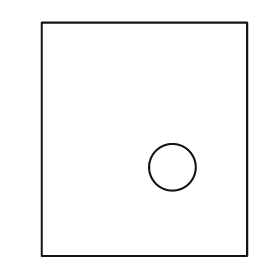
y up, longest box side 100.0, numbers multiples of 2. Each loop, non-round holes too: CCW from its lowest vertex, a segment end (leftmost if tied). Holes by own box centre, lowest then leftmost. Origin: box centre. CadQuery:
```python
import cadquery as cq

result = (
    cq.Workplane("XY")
    .moveTo(-44.0, -50.0)
    .lineTo(44.0, -50.0)
    .lineTo(44.0, 50.0)
    .lineTo(-44.0, 50.0)
    .close()
    .moveTo(12.0, -12.0)
    .circle(10.0)
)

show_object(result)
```